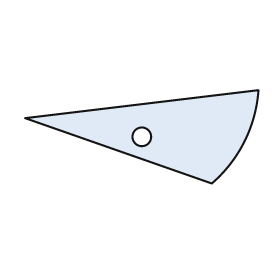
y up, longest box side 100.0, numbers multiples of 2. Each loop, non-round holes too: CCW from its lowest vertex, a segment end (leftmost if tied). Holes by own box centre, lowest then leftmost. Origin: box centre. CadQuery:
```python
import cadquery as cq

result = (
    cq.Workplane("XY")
    .moveTo(30.0, -20.0)
    .threePointArc((44.0, -2.0), (50.0, 20.0))
    .lineTo(-50.0, 8.0)
    .close()
    .moveTo(0.0, 0.0)
    .circle(4.0)
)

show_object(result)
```